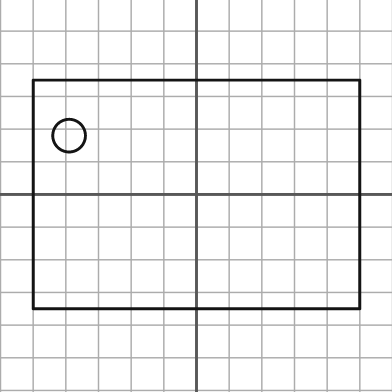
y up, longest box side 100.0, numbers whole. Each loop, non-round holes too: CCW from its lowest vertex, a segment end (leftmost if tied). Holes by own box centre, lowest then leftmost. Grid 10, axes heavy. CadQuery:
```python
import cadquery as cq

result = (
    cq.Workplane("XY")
    .moveTo(-50.0, -35.0)
    .lineTo(50.0, -35.0)
    .lineTo(50.0, 35.0)
    .lineTo(-50.0, 35.0)
    .close()
    .moveTo(-39.0, 18.0)
    .circle(5.0)
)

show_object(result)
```